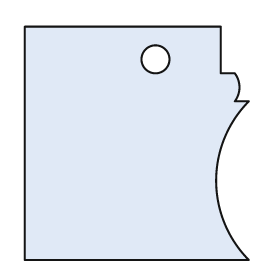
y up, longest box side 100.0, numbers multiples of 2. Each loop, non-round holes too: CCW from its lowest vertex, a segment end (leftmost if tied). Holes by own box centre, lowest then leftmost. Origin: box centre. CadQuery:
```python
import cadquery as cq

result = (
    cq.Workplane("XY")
    .moveTo(-48.0, -50.0)
    .lineTo(48.0, -50.0)
    .threePointArc((34.0, -16.0), (48.0, 18.0))
    .lineTo(42.0, 18.0)
    .threePointArc((44.0, 24.0), (42.0, 30.0))
    .lineTo(36.0, 30.0)
    .lineTo(36.0, 50.0)
    .lineTo(-48.0, 50.0)
    .close()
    .moveTo(8.0, 36.0)
    .circle(6.0)
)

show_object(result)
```